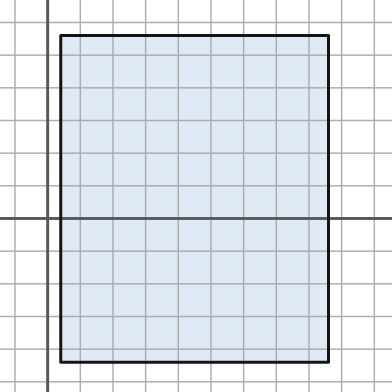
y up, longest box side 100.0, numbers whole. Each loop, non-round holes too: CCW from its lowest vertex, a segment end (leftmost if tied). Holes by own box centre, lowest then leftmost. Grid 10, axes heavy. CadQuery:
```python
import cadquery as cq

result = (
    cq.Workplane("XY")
    .moveTo(4.0, -44.0)
    .lineTo(86.0, -44.0)
    .lineTo(86.0, 56.0)
    .lineTo(4.0, 56.0)
    .close()
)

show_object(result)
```